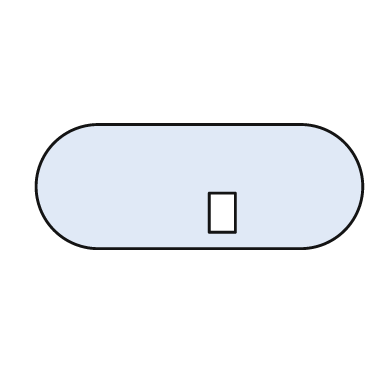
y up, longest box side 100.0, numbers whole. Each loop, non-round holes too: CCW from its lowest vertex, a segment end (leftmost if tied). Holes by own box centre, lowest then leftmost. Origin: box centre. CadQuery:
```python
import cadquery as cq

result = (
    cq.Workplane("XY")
    .moveTo(-31.0, -19.0)
    .lineTo(31.0, -19.0)
    .threePointArc((50.0, 0.0), (31.0, 19.0))
    .lineTo(-31.0, 19.0)
    .threePointArc((-50.0, 0.0), (-31.0, -19.0))
    .close()
    .moveTo(3.0, -14.0)
    .lineTo(11.0, -14.0)
    .lineTo(11.0, -2.0)
    .lineTo(3.0, -2.0)
    .close()
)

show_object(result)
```